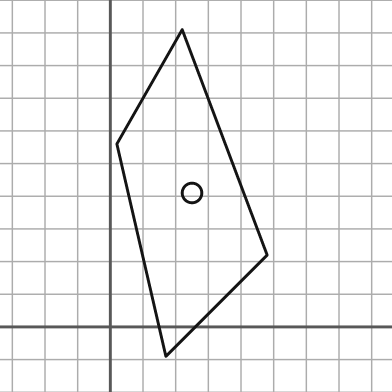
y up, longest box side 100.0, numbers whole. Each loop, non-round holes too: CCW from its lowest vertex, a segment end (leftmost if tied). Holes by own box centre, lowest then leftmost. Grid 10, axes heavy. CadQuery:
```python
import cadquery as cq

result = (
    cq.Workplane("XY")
    .moveTo(17.0, -9.0)
    .lineTo(48.0, 22.0)
    .lineTo(22.0, 91.0)
    .lineTo(2.0, 56.0)
    .close()
    .moveTo(25.0, 41.0)
    .circle(3.0)
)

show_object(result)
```